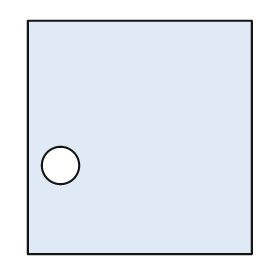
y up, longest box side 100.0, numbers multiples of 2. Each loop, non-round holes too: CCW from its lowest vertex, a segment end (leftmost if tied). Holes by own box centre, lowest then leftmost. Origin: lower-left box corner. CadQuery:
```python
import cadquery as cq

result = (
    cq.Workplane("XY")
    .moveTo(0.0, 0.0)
    .lineTo(96.0, 0.0)
    .lineTo(96.0, 100.0)
    .lineTo(0.0, 100.0)
    .close()
    .moveTo(14.0, 38.0)
    .circle(8.0)
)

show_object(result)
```